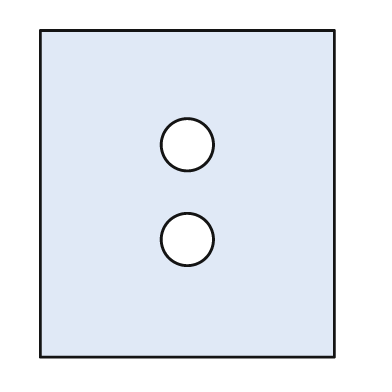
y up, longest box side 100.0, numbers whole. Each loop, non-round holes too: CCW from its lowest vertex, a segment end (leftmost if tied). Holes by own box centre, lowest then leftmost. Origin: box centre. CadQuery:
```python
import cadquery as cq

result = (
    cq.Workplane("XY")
    .moveTo(-45.0, -50.0)
    .lineTo(45.0, -50.0)
    .lineTo(45.0, 50.0)
    .lineTo(-45.0, 50.0)
    .close()
    .moveTo(0.0, -14.0)
    .circle(8.0)
    .moveTo(0.0, 15.0)
    .circle(8.0)
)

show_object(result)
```